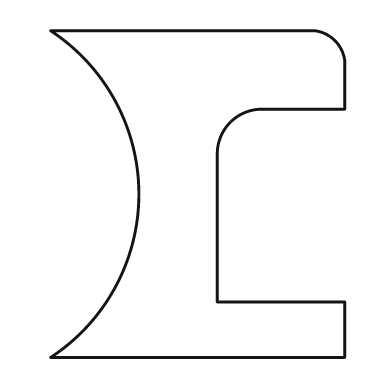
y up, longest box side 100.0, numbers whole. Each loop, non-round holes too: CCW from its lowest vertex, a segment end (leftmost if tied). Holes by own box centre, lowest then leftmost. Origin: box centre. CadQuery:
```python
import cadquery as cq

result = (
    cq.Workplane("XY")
    .moveTo(-45.0, -50.0)
    .lineTo(45.0, -50.0)
    .lineTo(45.0, -33.0)
    .lineTo(6.0, -33.0)
    .lineTo(6.0, 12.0)
    .threePointArc((10.0, 22.0), (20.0, 26.0))
    .lineTo(45.0, 26.0)
    .lineTo(45.0, 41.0)
    .threePointArc((42.0, 47.0), (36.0, 50.0))
    .lineTo(-45.0, 50.0)
    .threePointArc((-18.0, 0.0), (-45.0, -50.0))
    .close()
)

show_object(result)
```